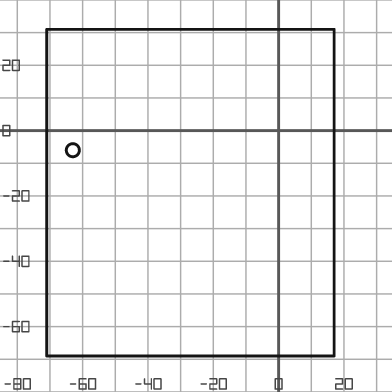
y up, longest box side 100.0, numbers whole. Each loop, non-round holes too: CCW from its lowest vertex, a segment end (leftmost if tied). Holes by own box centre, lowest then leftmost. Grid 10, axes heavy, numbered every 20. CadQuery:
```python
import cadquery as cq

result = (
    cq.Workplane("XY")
    .moveTo(-71.0, -69.0)
    .lineTo(17.0, -69.0)
    .lineTo(17.0, 31.0)
    .lineTo(-71.0, 31.0)
    .close()
    .moveTo(-63.0, -6.0)
    .circle(2.0)
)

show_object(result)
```